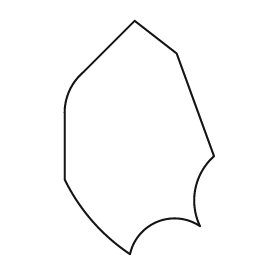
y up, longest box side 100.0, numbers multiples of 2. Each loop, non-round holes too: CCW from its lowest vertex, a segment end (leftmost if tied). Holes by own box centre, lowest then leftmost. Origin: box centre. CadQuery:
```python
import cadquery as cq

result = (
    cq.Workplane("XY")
    .moveTo(-4.0, -50.0)
    .threePointArc((8.0, -36.0), (26.0, -38.0))
    .threePointArc((24.0, -22.0), (32.0, -8.0))
    .lineTo(16.0, 36.0)
    .lineTo(-2.0, 50.0)
    .lineTo(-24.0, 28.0)
    .threePointArc((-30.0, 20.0), (-32.0, 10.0))
    .lineTo(-32.0, -18.0)
    .threePointArc((-20.0, -36.0), (-4.0, -50.0))
    .close()
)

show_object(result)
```